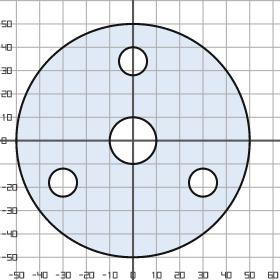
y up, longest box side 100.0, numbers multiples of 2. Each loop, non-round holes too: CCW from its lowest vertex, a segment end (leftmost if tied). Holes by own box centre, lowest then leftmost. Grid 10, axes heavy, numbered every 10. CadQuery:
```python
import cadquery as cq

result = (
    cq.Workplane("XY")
    .moveTo(0.0, 0.0)
    .circle(50.0)
    .moveTo(-30.0, -18.0)
    .circle(6.0)
    .moveTo(30.0, -18.0)
    .circle(6.0)
    .moveTo(0.0, 0.0)
    .circle(10.0)
    .moveTo(0.0, 34.0)
    .circle(6.0)
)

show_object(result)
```